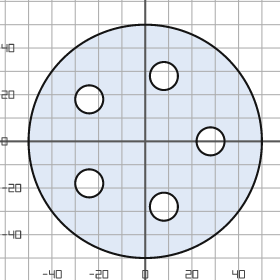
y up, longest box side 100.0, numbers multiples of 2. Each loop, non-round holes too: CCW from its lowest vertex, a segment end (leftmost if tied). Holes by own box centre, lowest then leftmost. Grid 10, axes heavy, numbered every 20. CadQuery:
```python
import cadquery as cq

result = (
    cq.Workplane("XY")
    .moveTo(0.0, 0.0)
    .circle(50.0)
    .moveTo(8.0, -28.0)
    .circle(6.0)
    .moveTo(-24.0, -18.0)
    .circle(6.0)
    .moveTo(28.0, 0.0)
    .circle(6.0)
    .moveTo(-24.0, 18.0)
    .circle(6.0)
    .moveTo(8.0, 28.0)
    .circle(6.0)
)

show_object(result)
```